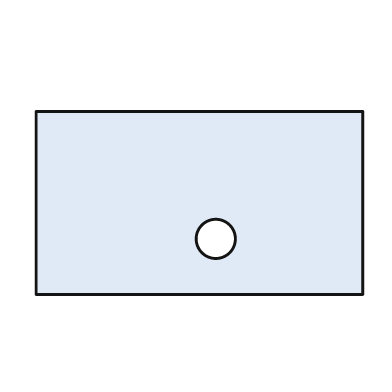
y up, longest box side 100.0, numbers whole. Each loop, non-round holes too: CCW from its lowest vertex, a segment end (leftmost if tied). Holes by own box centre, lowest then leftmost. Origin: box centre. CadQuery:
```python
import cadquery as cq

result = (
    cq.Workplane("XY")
    .moveTo(-50.0, -28.0)
    .lineTo(50.0, -28.0)
    .lineTo(50.0, 28.0)
    .lineTo(-50.0, 28.0)
    .close()
    .moveTo(5.0, -11.0)
    .circle(6.0)
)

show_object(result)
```